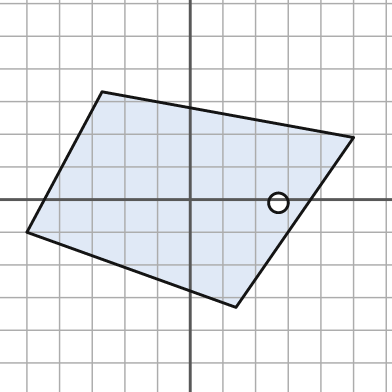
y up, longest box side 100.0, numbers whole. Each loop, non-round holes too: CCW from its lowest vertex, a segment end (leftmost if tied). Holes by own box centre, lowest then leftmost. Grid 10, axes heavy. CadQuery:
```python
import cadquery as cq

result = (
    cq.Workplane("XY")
    .moveTo(14.0, -33.0)
    .lineTo(50.0, 19.0)
    .lineTo(-27.0, 33.0)
    .lineTo(-50.0, -10.0)
    .close()
    .moveTo(27.0, -1.0)
    .circle(3.0)
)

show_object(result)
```